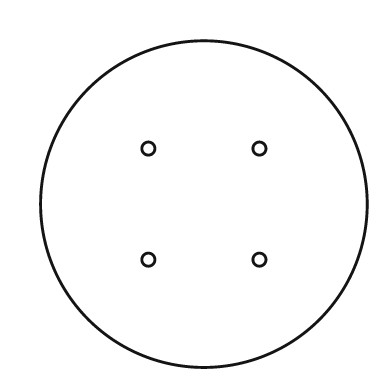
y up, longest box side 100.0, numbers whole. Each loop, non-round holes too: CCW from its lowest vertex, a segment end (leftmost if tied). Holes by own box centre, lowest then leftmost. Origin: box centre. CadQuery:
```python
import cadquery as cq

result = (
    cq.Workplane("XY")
    .moveTo(0.0, 0.0)
    .circle(50.0)
    .moveTo(-17.0, -17.0)
    .circle(2.0)
    .moveTo(17.0, -17.0)
    .circle(2.0)
    .moveTo(-17.0, 17.0)
    .circle(2.0)
    .moveTo(17.0, 17.0)
    .circle(2.0)
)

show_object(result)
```